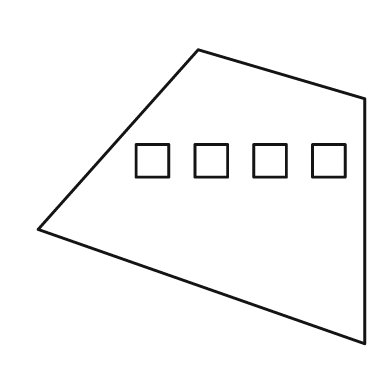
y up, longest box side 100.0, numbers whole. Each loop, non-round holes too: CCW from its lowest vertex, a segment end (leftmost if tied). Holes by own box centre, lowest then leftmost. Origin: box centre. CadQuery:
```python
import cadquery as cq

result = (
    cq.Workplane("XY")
    .moveTo(50.0, -45.0)
    .lineTo(50.0, 30.0)
    .lineTo(-1.0, 45.0)
    .lineTo(-50.0, -10.0)
    .close()
    .moveTo(-20.0, 6.0)
    .lineTo(-10.0, 6.0)
    .lineTo(-10.0, 16.0)
    .lineTo(-20.0, 16.0)
    .close()
    .moveTo(-2.0, 6.0)
    .lineTo(8.0, 6.0)
    .lineTo(8.0, 16.0)
    .lineTo(-2.0, 16.0)
    .close()
    .moveTo(16.0, 6.0)
    .lineTo(26.0, 6.0)
    .lineTo(26.0, 16.0)
    .lineTo(16.0, 16.0)
    .close()
    .moveTo(34.0, 6.0)
    .lineTo(44.0, 6.0)
    .lineTo(44.0, 16.0)
    .lineTo(34.0, 16.0)
    .close()
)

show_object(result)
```